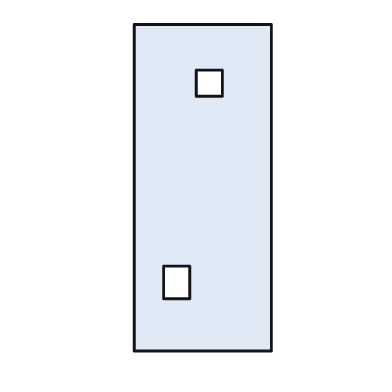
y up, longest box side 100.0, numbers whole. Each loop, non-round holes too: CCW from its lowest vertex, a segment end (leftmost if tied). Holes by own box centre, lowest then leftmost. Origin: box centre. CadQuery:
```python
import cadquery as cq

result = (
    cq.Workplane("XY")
    .moveTo(-21.0, -50.0)
    .lineTo(21.0, -50.0)
    .lineTo(21.0, 50.0)
    .lineTo(-21.0, 50.0)
    .close()
    .moveTo(-12.0, -34.0)
    .lineTo(-4.0, -34.0)
    .lineTo(-4.0, -24.0)
    .lineTo(-12.0, -24.0)
    .close()
    .moveTo(-2.0, 28.0)
    .lineTo(6.0, 28.0)
    .lineTo(6.0, 36.0)
    .lineTo(-2.0, 36.0)
    .close()
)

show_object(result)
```